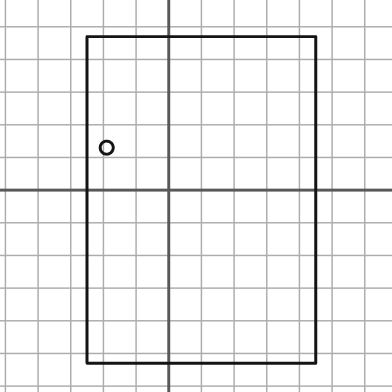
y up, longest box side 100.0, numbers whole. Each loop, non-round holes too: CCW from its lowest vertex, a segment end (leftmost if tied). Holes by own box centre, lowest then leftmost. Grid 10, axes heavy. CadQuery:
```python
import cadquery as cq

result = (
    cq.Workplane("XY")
    .moveTo(-25.0, -53.0)
    .lineTo(45.0, -53.0)
    .lineTo(45.0, 47.0)
    .lineTo(-25.0, 47.0)
    .close()
    .moveTo(-19.0, 13.0)
    .circle(2.0)
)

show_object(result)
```